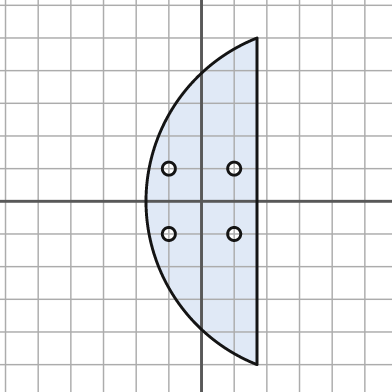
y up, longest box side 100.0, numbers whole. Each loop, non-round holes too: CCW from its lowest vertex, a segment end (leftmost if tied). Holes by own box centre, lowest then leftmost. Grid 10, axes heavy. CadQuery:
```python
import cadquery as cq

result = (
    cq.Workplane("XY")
    .moveTo(17.0, -50.0)
    .lineTo(17.0, 50.0)
    .threePointArc((-17.0, 0.0), (17.0, -50.0))
    .close()
    .moveTo(-10.0, -10.0)
    .circle(2.0)
    .moveTo(10.0, -10.0)
    .circle(2.0)
    .moveTo(-10.0, 10.0)
    .circle(2.0)
    .moveTo(10.0, 10.0)
    .circle(2.0)
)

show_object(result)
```